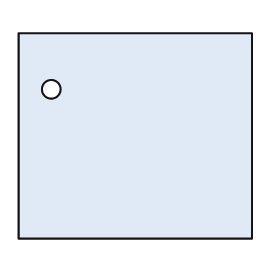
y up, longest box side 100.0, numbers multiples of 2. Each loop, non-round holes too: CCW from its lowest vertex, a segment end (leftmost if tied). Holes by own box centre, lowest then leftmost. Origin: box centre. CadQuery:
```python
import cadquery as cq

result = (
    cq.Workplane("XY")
    .moveTo(-50.0, -44.0)
    .lineTo(50.0, -44.0)
    .lineTo(50.0, 44.0)
    .lineTo(-50.0, 44.0)
    .close()
    .moveTo(-36.0, 20.0)
    .circle(4.0)
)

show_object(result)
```